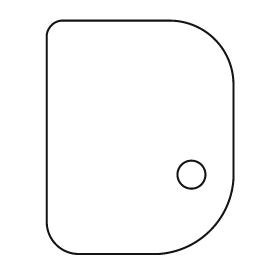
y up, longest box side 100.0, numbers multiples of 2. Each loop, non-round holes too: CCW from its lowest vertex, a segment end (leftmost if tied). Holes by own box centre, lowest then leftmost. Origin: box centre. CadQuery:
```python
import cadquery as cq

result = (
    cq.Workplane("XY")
    .moveTo(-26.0, -50.0)
    .lineTo(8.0, -50.0)
    .threePointArc((30.0, -40.0), (40.0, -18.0))
    .lineTo(40.0, 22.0)
    .threePointArc((32.0, 42.0), (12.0, 50.0))
    .lineTo(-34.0, 50.0)
    .threePointArc((-38.0, 48.0), (-40.0, 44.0))
    .lineTo(-40.0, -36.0)
    .threePointArc((-36.0, -46.0), (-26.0, -50.0))
    .close()
    .moveTo(22.0, -16.0)
    .circle(6.0)
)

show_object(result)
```